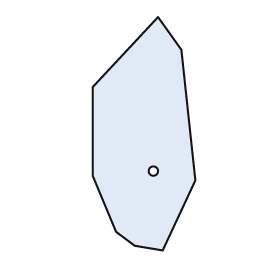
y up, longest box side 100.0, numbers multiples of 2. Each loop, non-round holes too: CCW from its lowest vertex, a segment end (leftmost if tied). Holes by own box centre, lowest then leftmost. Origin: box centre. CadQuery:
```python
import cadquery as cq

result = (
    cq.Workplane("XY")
    .moveTo(8.0, -50.0)
    .lineTo(22.0, -20.0)
    .lineTo(16.0, 36.0)
    .lineTo(6.0, 50.0)
    .lineTo(-22.0, 20.0)
    .lineTo(-22.0, -18.0)
    .lineTo(-12.0, -42.0)
    .lineTo(-4.0, -48.0)
    .close()
    .moveTo(4.0, -16.0)
    .circle(2.0)
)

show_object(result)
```